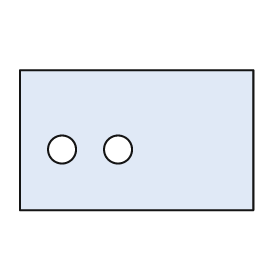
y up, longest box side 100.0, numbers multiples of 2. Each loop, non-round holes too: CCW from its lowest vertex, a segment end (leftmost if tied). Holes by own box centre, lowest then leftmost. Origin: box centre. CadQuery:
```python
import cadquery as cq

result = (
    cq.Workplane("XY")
    .moveTo(-50.0, -30.0)
    .lineTo(50.0, -30.0)
    .lineTo(50.0, 30.0)
    .lineTo(-50.0, 30.0)
    .close()
    .moveTo(-32.0, -4.0)
    .circle(6.0)
    .moveTo(-8.0, -4.0)
    .circle(6.0)
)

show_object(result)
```